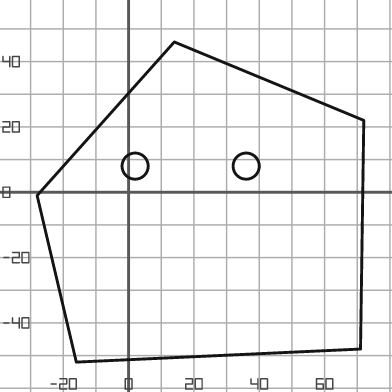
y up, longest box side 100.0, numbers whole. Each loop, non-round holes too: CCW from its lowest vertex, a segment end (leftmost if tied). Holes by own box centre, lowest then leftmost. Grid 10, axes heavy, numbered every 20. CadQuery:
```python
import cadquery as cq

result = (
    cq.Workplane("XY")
    .moveTo(-16.0, -52.0)
    .lineTo(71.0, -48.0)
    .lineTo(72.0, 22.0)
    .lineTo(14.0, 46.0)
    .lineTo(-28.0, -1.0)
    .close()
    .moveTo(2.0, 8.0)
    .circle(4.0)
    .moveTo(36.0, 8.0)
    .circle(4.0)
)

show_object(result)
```